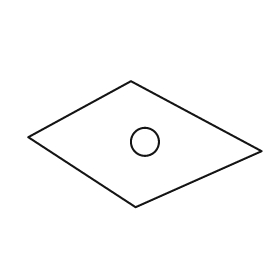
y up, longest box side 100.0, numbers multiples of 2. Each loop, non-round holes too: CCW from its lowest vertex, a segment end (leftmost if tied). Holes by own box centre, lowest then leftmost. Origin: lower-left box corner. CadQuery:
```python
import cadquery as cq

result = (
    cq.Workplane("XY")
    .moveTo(46.0, 0.0)
    .lineTo(100.0, 24.0)
    .lineTo(44.0, 54.0)
    .lineTo(0.0, 30.0)
    .close()
    .moveTo(50.0, 28.0)
    .circle(6.0)
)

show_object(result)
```